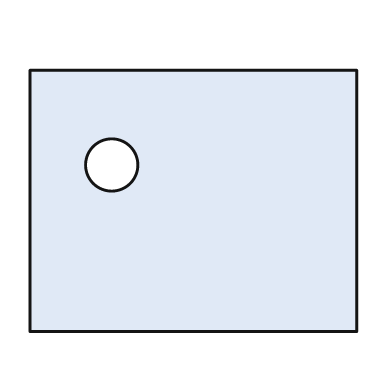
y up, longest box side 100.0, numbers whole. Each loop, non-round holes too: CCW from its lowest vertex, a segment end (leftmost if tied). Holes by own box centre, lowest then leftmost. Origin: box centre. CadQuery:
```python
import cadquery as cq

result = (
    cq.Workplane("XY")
    .moveTo(-50.0, -40.0)
    .lineTo(50.0, -40.0)
    .lineTo(50.0, 40.0)
    .lineTo(-50.0, 40.0)
    .close()
    .moveTo(-25.0, 11.0)
    .circle(8.0)
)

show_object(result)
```